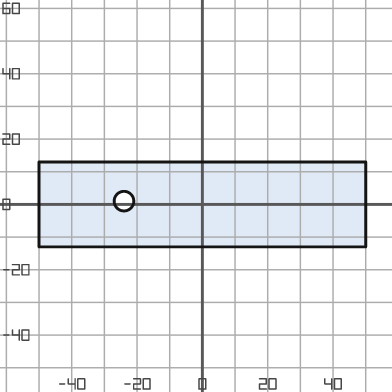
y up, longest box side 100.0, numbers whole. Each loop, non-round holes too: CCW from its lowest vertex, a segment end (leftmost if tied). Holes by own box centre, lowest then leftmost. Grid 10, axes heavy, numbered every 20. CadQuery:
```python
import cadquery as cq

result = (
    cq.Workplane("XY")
    .moveTo(-50.0, -13.0)
    .lineTo(50.0, -13.0)
    .lineTo(50.0, 13.0)
    .lineTo(-50.0, 13.0)
    .close()
    .moveTo(-24.0, 1.0)
    .circle(3.0)
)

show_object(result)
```